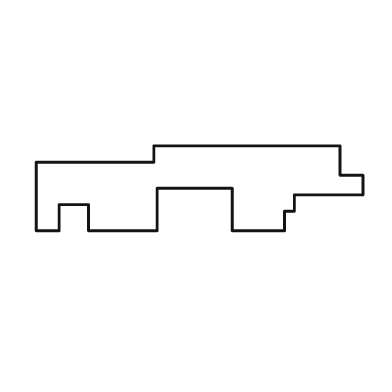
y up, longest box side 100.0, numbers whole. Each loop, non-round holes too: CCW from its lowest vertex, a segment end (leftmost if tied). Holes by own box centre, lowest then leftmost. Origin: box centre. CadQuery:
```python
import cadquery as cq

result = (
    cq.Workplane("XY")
    .moveTo(-50.0, -13.0)
    .lineTo(-43.0, -13.0)
    .lineTo(-43.0, -5.0)
    .lineTo(-34.0, -5.0)
    .lineTo(-34.0, -13.0)
    .lineTo(-13.0, -13.0)
    .lineTo(-13.0, 0.0)
    .lineTo(10.0, 0.0)
    .lineTo(10.0, -13.0)
    .lineTo(26.0, -13.0)
    .lineTo(26.0, -7.0)
    .lineTo(29.0, -7.0)
    .lineTo(29.0, -2.0)
    .lineTo(50.0, -2.0)
    .lineTo(50.0, 4.0)
    .lineTo(43.0, 4.0)
    .lineTo(43.0, 13.0)
    .lineTo(-14.0, 13.0)
    .lineTo(-14.0, 8.0)
    .lineTo(-50.0, 8.0)
    .close()
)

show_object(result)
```